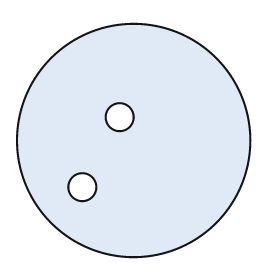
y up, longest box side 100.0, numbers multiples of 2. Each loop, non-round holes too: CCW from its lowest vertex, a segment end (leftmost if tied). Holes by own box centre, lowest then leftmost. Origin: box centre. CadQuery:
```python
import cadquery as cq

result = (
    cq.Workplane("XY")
    .moveTo(0.0, 0.0)
    .circle(50.0)
    .moveTo(-22.0, -20.0)
    .circle(6.0)
    .moveTo(-6.0, 10.0)
    .circle(6.0)
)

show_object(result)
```